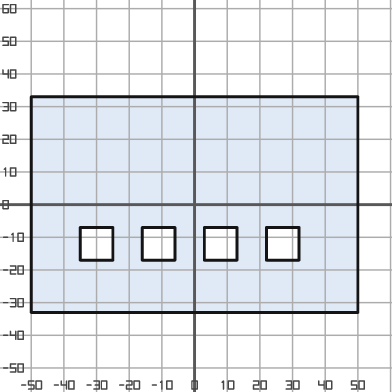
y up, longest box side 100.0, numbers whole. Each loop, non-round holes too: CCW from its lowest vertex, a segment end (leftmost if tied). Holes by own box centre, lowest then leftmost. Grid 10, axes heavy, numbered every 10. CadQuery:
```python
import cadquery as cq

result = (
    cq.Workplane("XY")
    .moveTo(-50.0, -33.0)
    .lineTo(50.0, -33.0)
    .lineTo(50.0, 33.0)
    .lineTo(-50.0, 33.0)
    .close()
    .moveTo(-35.0, -17.0)
    .lineTo(-25.0, -17.0)
    .lineTo(-25.0, -7.0)
    .lineTo(-35.0, -7.0)
    .close()
    .moveTo(-16.0, -17.0)
    .lineTo(-6.0, -17.0)
    .lineTo(-6.0, -7.0)
    .lineTo(-16.0, -7.0)
    .close()
    .moveTo(3.0, -17.0)
    .lineTo(13.0, -17.0)
    .lineTo(13.0, -7.0)
    .lineTo(3.0, -7.0)
    .close()
    .moveTo(22.0, -17.0)
    .lineTo(32.0, -17.0)
    .lineTo(32.0, -7.0)
    .lineTo(22.0, -7.0)
    .close()
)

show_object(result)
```